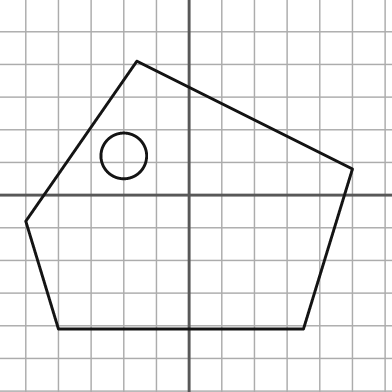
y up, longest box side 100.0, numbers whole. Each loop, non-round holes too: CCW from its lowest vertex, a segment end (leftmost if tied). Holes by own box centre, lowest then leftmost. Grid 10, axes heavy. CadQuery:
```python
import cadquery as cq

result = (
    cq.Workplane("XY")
    .moveTo(-40.0, -41.0)
    .lineTo(35.0, -41.0)
    .lineTo(50.0, 8.0)
    .lineTo(-16.0, 41.0)
    .lineTo(-50.0, -8.0)
    .close()
    .moveTo(-20.0, 12.0)
    .circle(7.0)
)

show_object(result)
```